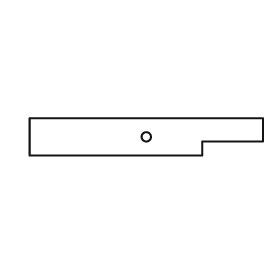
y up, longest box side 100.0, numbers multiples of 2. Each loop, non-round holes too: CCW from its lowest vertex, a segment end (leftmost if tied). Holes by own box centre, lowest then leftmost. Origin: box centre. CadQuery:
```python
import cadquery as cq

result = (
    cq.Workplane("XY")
    .moveTo(-50.0, -8.0)
    .lineTo(24.0, -8.0)
    .lineTo(24.0, -2.0)
    .lineTo(50.0, -2.0)
    .lineTo(50.0, 8.0)
    .lineTo(-50.0, 8.0)
    .close()
    .moveTo(0.0, 0.0)
    .circle(2.0)
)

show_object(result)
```